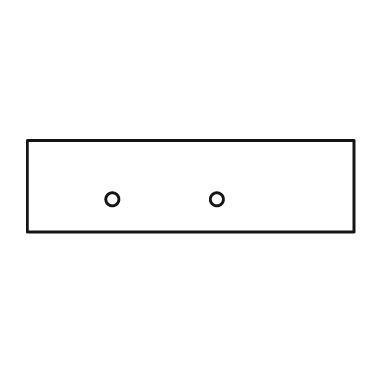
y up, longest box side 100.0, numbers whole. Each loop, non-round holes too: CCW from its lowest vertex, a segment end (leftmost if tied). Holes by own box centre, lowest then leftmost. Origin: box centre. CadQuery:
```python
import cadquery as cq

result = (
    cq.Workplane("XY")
    .moveTo(-50.0, -14.0)
    .lineTo(50.0, -14.0)
    .lineTo(50.0, 14.0)
    .lineTo(-50.0, 14.0)
    .close()
    .moveTo(-24.0, -4.0)
    .circle(2.0)
    .moveTo(8.0, -4.0)
    .circle(2.0)
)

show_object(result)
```